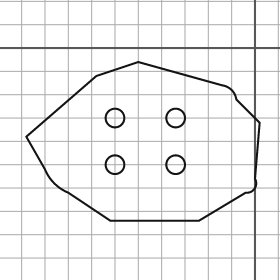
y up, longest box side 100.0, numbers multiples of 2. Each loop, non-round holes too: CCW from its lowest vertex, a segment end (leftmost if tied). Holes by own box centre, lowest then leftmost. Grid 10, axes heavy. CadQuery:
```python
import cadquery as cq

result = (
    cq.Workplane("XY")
    .moveTo(-62.0, -74.0)
    .lineTo(-24.0, -74.0)
    .lineTo(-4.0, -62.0)
    .threePointArc((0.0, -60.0), (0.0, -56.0))
    .lineTo(2.0, -32.0)
    .lineTo(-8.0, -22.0)
    .threePointArc((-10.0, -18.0), (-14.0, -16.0))
    .lineTo(-50.0, -6.0)
    .lineTo(-68.0, -12.0)
    .lineTo(-98.0, -38.0)
    .lineTo(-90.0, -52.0)
    .threePointArc((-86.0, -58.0), (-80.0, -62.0))
    .close()
    .moveTo(-60.0, -50.0)
    .circle(4.0)
    .moveTo(-34.0, -50.0)
    .circle(4.0)
    .moveTo(-60.0, -30.0)
    .circle(4.0)
    .moveTo(-34.0, -30.0)
    .circle(4.0)
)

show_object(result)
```